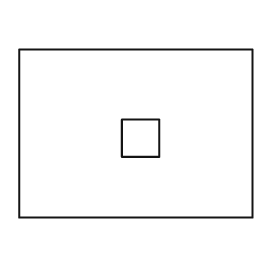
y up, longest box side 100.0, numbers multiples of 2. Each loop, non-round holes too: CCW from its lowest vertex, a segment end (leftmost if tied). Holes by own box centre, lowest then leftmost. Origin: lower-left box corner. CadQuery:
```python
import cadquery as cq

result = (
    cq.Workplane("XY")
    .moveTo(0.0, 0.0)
    .lineTo(100.0, 0.0)
    .lineTo(100.0, 72.0)
    .lineTo(0.0, 72.0)
    .close()
    .moveTo(44.0, 26.0)
    .lineTo(60.0, 26.0)
    .lineTo(60.0, 42.0)
    .lineTo(44.0, 42.0)
    .close()
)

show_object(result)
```